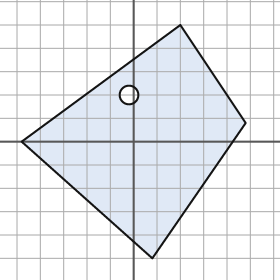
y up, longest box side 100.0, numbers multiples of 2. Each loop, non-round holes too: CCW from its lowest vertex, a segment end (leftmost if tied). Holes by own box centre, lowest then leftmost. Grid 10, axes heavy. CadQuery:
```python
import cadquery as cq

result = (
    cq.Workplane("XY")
    .moveTo(8.0, -50.0)
    .lineTo(48.0, 8.0)
    .lineTo(20.0, 50.0)
    .lineTo(-48.0, 0.0)
    .close()
    .moveTo(-2.0, 20.0)
    .circle(4.0)
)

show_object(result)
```